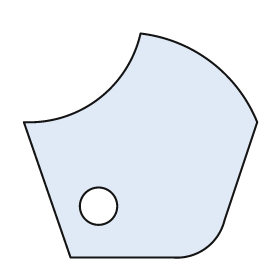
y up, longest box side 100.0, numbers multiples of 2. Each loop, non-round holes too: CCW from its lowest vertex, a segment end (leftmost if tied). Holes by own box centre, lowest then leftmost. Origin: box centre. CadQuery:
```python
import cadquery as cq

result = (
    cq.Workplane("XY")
    .moveTo(-30.0, -48.0)
    .lineTo(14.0, -48.0)
    .threePointArc((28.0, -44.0), (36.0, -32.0))
    .lineTo(50.0, 10.0)
    .threePointArc((30.0, 36.0), (0.0, 48.0))
    .threePointArc((-18.0, 20.0), (-50.0, 10.0))
    .close()
    .moveTo(-18.0, -26.0)
    .circle(8.0)
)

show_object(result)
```